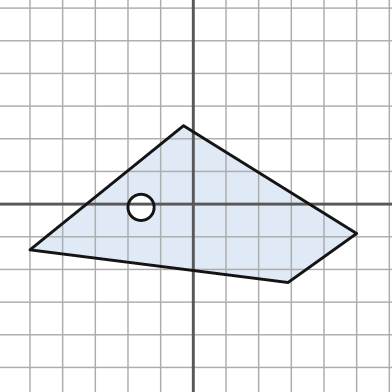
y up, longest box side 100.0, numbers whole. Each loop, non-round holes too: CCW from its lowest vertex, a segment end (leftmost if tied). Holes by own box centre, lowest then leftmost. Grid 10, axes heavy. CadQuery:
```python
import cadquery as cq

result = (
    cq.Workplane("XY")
    .moveTo(29.0, -24.0)
    .lineTo(50.0, -9.0)
    .lineTo(-3.0, 24.0)
    .lineTo(-50.0, -14.0)
    .close()
    .moveTo(-16.0, -1.0)
    .circle(4.0)
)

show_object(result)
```